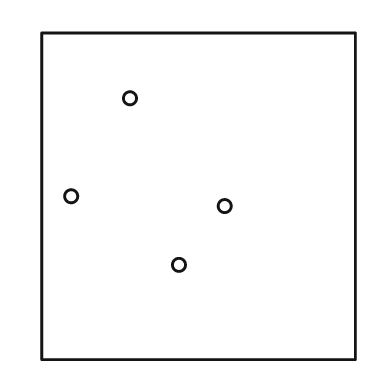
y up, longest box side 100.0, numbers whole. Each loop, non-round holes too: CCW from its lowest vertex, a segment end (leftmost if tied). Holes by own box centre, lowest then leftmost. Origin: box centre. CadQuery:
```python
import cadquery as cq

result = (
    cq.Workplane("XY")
    .moveTo(-48.0, -50.0)
    .lineTo(48.0, -50.0)
    .lineTo(48.0, 50.0)
    .lineTo(-48.0, 50.0)
    .close()
    .moveTo(-6.0, -21.0)
    .circle(2.0)
    .moveTo(8.0, -3.0)
    .circle(2.0)
    .moveTo(-39.0, 0.0)
    .circle(2.0)
    .moveTo(-21.0, 30.0)
    .circle(2.0)
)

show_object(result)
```